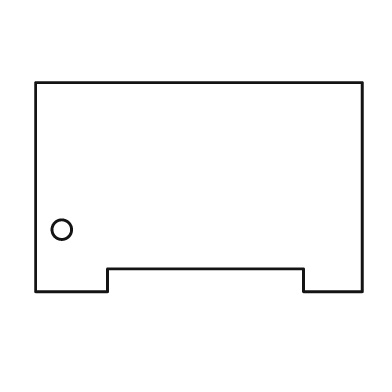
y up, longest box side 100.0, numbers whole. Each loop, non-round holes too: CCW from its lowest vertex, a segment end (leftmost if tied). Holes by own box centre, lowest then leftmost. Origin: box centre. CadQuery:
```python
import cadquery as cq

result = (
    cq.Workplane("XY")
    .moveTo(-50.0, -32.0)
    .lineTo(-28.0, -32.0)
    .lineTo(-28.0, -25.0)
    .lineTo(32.0, -25.0)
    .lineTo(32.0, -32.0)
    .lineTo(50.0, -32.0)
    .lineTo(50.0, 32.0)
    .lineTo(-50.0, 32.0)
    .close()
    .moveTo(-42.0, -13.0)
    .circle(3.0)
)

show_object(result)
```